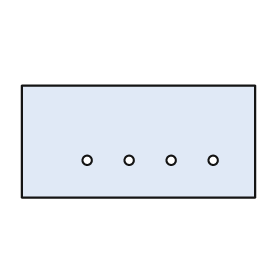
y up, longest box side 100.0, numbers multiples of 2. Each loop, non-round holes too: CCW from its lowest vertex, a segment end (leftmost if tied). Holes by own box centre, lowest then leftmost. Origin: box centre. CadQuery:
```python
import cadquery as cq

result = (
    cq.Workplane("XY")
    .moveTo(-50.0, -24.0)
    .lineTo(50.0, -24.0)
    .lineTo(50.0, 24.0)
    .lineTo(-50.0, 24.0)
    .close()
    .moveTo(-22.0, -8.0)
    .circle(2.0)
    .moveTo(-4.0, -8.0)
    .circle(2.0)
    .moveTo(14.0, -8.0)
    .circle(2.0)
    .moveTo(32.0, -8.0)
    .circle(2.0)
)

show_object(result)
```